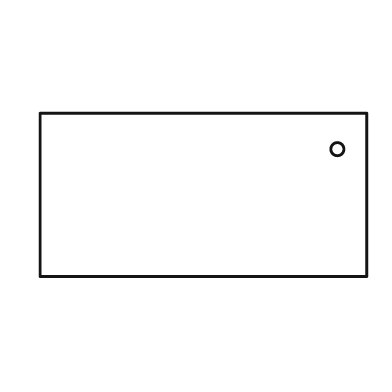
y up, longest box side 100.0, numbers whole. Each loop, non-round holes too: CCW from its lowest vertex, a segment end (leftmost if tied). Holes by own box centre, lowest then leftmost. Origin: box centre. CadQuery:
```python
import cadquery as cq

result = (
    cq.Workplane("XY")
    .moveTo(-50.0, -25.0)
    .lineTo(50.0, -25.0)
    .lineTo(50.0, 25.0)
    .lineTo(-50.0, 25.0)
    .close()
    .moveTo(41.0, 14.0)
    .circle(2.0)
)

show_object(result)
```